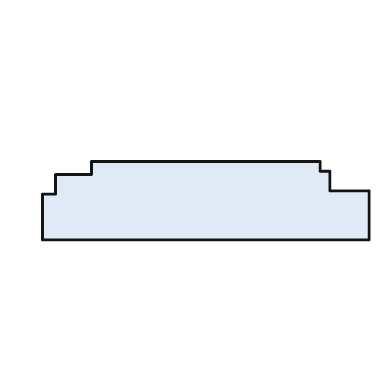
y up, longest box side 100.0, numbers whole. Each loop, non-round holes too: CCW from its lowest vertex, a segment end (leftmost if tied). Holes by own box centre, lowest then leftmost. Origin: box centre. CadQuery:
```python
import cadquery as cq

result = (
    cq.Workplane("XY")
    .moveTo(-50.0, -12.0)
    .lineTo(50.0, -12.0)
    .lineTo(50.0, 3.0)
    .lineTo(38.0, 3.0)
    .lineTo(38.0, 9.0)
    .lineTo(35.0, 9.0)
    .lineTo(35.0, 12.0)
    .lineTo(-35.0, 12.0)
    .lineTo(-35.0, 8.0)
    .lineTo(-46.0, 8.0)
    .lineTo(-46.0, 2.0)
    .lineTo(-50.0, 2.0)
    .close()
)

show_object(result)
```